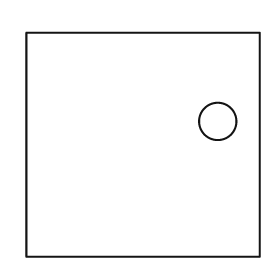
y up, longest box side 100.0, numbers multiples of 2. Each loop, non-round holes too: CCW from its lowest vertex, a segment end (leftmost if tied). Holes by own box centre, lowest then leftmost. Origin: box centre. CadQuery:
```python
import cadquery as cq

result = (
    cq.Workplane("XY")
    .moveTo(-50.0, -48.0)
    .lineTo(50.0, -48.0)
    .lineTo(50.0, 48.0)
    .lineTo(-50.0, 48.0)
    .close()
    .moveTo(32.0, 10.0)
    .circle(8.0)
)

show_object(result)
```